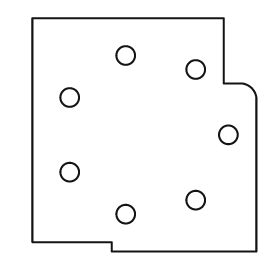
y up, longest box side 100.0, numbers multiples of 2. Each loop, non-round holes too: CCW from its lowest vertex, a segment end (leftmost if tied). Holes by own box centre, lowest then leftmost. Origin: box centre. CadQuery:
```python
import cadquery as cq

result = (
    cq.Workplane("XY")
    .moveTo(-14.0, -50.0)
    .lineTo(48.0, -50.0)
    .lineTo(48.0, 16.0)
    .threePointArc((46.0, 20.0), (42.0, 22.0))
    .lineTo(34.0, 22.0)
    .lineTo(34.0, 50.0)
    .lineTo(-48.0, 50.0)
    .lineTo(-48.0, -46.0)
    .lineTo(-14.0, -46.0)
    .close()
    .moveTo(-8.0, -34.0)
    .circle(4.0)
    .moveTo(22.0, -28.0)
    .circle(4.0)
    .moveTo(-32.0, -16.0)
    .circle(4.0)
    .moveTo(36.0, 0.0)
    .circle(4.0)
    .moveTo(-32.0, 16.0)
    .circle(4.0)
    .moveTo(22.0, 28.0)
    .circle(4.0)
    .moveTo(-8.0, 34.0)
    .circle(4.0)
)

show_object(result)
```